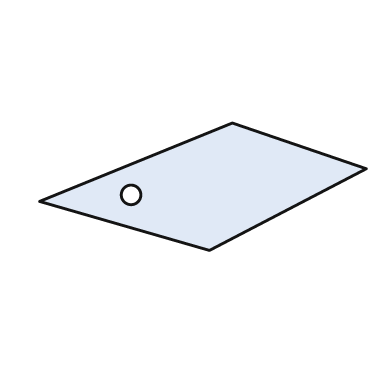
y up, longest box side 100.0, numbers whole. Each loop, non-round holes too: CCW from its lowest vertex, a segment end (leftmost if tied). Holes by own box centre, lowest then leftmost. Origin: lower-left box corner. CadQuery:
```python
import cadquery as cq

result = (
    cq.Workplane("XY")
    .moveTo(52.0, 0.0)
    .lineTo(100.0, 25.0)
    .lineTo(59.0, 39.0)
    .lineTo(0.0, 15.0)
    .close()
    .moveTo(28.0, 17.0)
    .circle(3.0)
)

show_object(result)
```